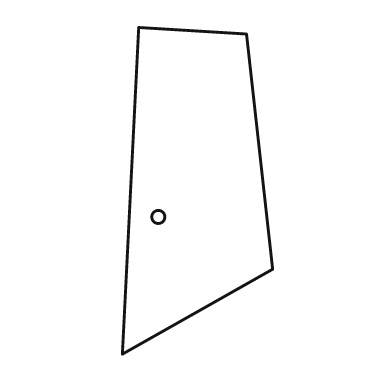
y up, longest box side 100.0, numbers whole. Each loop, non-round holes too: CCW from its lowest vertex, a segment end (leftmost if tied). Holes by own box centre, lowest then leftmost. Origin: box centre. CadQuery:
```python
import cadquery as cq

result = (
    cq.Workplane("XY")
    .moveTo(-23.0, -50.0)
    .lineTo(23.0, -24.0)
    .lineTo(15.0, 48.0)
    .lineTo(-18.0, 50.0)
    .close()
    .moveTo(-12.0, -8.0)
    .circle(2.0)
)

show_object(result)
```